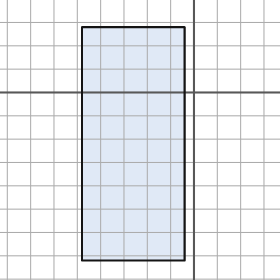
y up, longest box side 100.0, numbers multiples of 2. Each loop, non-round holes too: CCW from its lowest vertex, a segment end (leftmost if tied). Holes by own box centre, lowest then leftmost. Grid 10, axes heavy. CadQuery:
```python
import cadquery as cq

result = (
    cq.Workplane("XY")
    .moveTo(-48.0, -72.0)
    .lineTo(-4.0, -72.0)
    .lineTo(-4.0, 28.0)
    .lineTo(-48.0, 28.0)
    .close()
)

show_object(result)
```